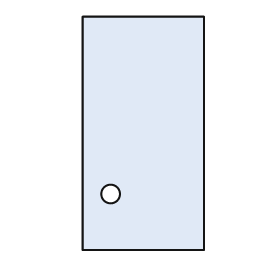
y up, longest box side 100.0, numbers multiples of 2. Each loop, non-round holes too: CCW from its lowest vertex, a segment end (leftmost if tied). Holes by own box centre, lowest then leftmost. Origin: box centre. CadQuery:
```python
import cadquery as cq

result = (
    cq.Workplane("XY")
    .moveTo(-26.0, -50.0)
    .lineTo(26.0, -50.0)
    .lineTo(26.0, 50.0)
    .lineTo(-26.0, 50.0)
    .close()
    .moveTo(-14.0, -26.0)
    .circle(4.0)
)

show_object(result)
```